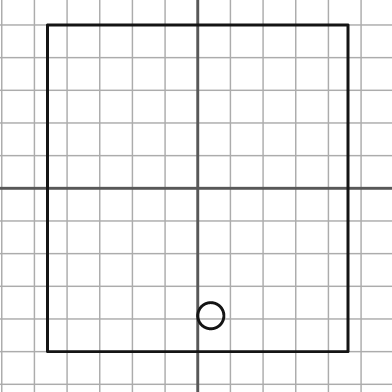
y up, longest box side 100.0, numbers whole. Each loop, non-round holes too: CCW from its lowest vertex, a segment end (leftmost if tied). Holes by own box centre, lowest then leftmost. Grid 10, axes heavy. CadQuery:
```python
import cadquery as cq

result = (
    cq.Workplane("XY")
    .moveTo(-46.0, -50.0)
    .lineTo(46.0, -50.0)
    .lineTo(46.0, 50.0)
    .lineTo(-46.0, 50.0)
    .close()
    .moveTo(4.0, -39.0)
    .circle(4.0)
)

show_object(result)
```